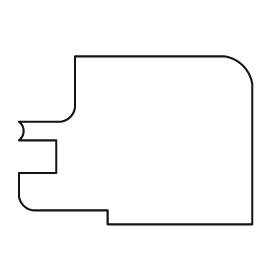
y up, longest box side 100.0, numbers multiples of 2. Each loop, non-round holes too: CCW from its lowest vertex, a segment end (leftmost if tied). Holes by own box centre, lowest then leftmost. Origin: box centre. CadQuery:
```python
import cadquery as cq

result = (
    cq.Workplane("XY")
    .moveTo(-12.0, -36.0)
    .lineTo(50.0, -36.0)
    .lineTo(50.0, 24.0)
    .threePointArc((46.0, 32.0), (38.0, 36.0))
    .lineTo(-26.0, 36.0)
    .lineTo(-26.0, 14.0)
    .threePointArc((-28.0, 10.0), (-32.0, 8.0))
    .lineTo(-50.0, 8.0)
    .threePointArc((-48.0, 4.0), (-50.0, 0.0))
    .lineTo(-34.0, 0.0)
    .lineTo(-34.0, -14.0)
    .lineTo(-50.0, -14.0)
    .lineTo(-50.0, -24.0)
    .threePointArc((-48.0, -28.0), (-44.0, -30.0))
    .lineTo(-12.0, -30.0)
    .close()
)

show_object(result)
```